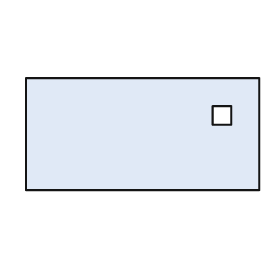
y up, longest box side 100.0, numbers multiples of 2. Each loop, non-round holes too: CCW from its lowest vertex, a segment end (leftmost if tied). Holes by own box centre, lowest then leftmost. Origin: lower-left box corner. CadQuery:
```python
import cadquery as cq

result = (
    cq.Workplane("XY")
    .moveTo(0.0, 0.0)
    .lineTo(100.0, 0.0)
    .lineTo(100.0, 48.0)
    .lineTo(0.0, 48.0)
    .close()
    .moveTo(80.0, 28.0)
    .lineTo(88.0, 28.0)
    .lineTo(88.0, 36.0)
    .lineTo(80.0, 36.0)
    .close()
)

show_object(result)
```